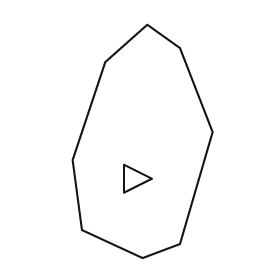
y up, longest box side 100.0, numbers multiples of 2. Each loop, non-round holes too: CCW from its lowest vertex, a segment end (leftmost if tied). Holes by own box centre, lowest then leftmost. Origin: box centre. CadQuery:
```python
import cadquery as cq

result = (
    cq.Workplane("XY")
    .moveTo(0.0, -50.0)
    .lineTo(16.0, -44.0)
    .lineTo(30.0, 4.0)
    .lineTo(16.0, 40.0)
    .lineTo(2.0, 50.0)
    .lineTo(-16.0, 34.0)
    .lineTo(-30.0, -8.0)
    .lineTo(-26.0, -38.0)
    .close()
    .moveTo(-8.0, -22.0)
    .lineTo(4.0, -16.0)
    .lineTo(-8.0, -10.0)
    .close()
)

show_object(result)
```